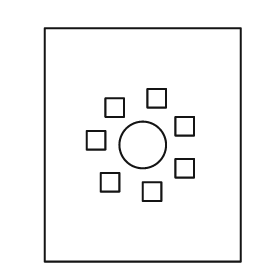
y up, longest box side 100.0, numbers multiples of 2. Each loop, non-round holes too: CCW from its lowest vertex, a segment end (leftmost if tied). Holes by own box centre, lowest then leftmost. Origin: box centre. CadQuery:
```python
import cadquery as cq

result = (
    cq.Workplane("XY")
    .moveTo(-42.0, -50.0)
    .lineTo(42.0, -50.0)
    .lineTo(42.0, 50.0)
    .lineTo(-42.0, 50.0)
    .close()
    .moveTo(0.0, -24.0)
    .lineTo(8.0, -24.0)
    .lineTo(8.0, -16.0)
    .lineTo(0.0, -16.0)
    .close()
    .moveTo(-18.0, -20.0)
    .lineTo(-10.0, -20.0)
    .lineTo(-10.0, -12.0)
    .lineTo(-18.0, -12.0)
    .close()
    .moveTo(14.0, -14.0)
    .lineTo(22.0, -14.0)
    .lineTo(22.0, -6.0)
    .lineTo(14.0, -6.0)
    .close()
    .moveTo(0.0, 0.0)
    .circle(10.0)
    .moveTo(-24.0, -2.0)
    .lineTo(-16.0, -2.0)
    .lineTo(-16.0, 6.0)
    .lineTo(-24.0, 6.0)
    .close()
    .moveTo(14.0, 4.0)
    .lineTo(22.0, 4.0)
    .lineTo(22.0, 12.0)
    .lineTo(14.0, 12.0)
    .close()
    .moveTo(-16.0, 12.0)
    .lineTo(-8.0, 12.0)
    .lineTo(-8.0, 20.0)
    .lineTo(-16.0, 20.0)
    .close()
    .moveTo(2.0, 16.0)
    .lineTo(10.0, 16.0)
    .lineTo(10.0, 24.0)
    .lineTo(2.0, 24.0)
    .close()
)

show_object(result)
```